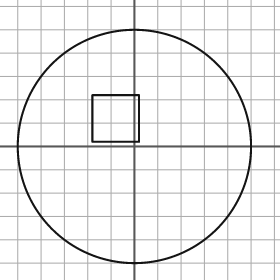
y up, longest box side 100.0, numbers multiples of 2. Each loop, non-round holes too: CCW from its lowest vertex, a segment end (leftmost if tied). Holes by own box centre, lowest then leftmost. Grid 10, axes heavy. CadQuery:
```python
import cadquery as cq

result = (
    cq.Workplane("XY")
    .moveTo(0.0, 0.0)
    .circle(50.0)
    .moveTo(-18.0, 2.0)
    .lineTo(2.0, 2.0)
    .lineTo(2.0, 22.0)
    .lineTo(-18.0, 22.0)
    .close()
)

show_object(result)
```